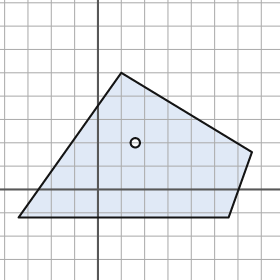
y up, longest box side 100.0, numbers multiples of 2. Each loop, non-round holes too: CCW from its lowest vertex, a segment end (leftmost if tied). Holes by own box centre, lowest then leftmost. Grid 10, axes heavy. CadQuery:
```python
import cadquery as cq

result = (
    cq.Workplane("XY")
    .moveTo(-34.0, -12.0)
    .lineTo(56.0, -12.0)
    .lineTo(66.0, 16.0)
    .lineTo(10.0, 50.0)
    .close()
    .moveTo(16.0, 20.0)
    .circle(2.0)
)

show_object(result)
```